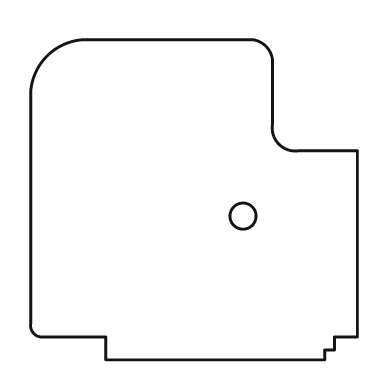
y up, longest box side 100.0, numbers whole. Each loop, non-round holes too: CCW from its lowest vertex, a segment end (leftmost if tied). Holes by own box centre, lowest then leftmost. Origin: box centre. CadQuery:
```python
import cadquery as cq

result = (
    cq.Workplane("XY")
    .moveTo(-27.0, -49.0)
    .lineTo(40.0, -49.0)
    .lineTo(40.0, -46.0)
    .lineTo(43.0, -46.0)
    .lineTo(43.0, -42.0)
    .lineTo(50.0, -42.0)
    .lineTo(50.0, 15.0)
    .lineTo(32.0, 15.0)
    .threePointArc((26.0, 17.0), (24.0, 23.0))
    .lineTo(24.0, 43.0)
    .threePointArc((22.0, 47.0), (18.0, 49.0))
    .lineTo(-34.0, 49.0)
    .threePointArc((-45.0, 44.0), (-50.0, 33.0))
    .lineTo(-50.0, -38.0)
    .threePointArc((-49.0, -41.0), (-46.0, -42.0))
    .lineTo(-27.0, -42.0)
    .close()
    .moveTo(15.0, -5.0)
    .circle(4.0)
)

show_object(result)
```